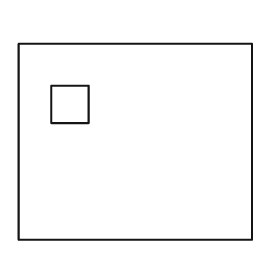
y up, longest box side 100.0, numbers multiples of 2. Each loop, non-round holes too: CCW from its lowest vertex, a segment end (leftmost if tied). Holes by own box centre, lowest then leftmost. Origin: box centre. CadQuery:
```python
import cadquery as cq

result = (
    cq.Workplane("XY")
    .moveTo(-50.0, -42.0)
    .lineTo(50.0, -42.0)
    .lineTo(50.0, 42.0)
    .lineTo(-50.0, 42.0)
    .close()
    .moveTo(-36.0, 8.0)
    .lineTo(-20.0, 8.0)
    .lineTo(-20.0, 24.0)
    .lineTo(-36.0, 24.0)
    .close()
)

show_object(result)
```